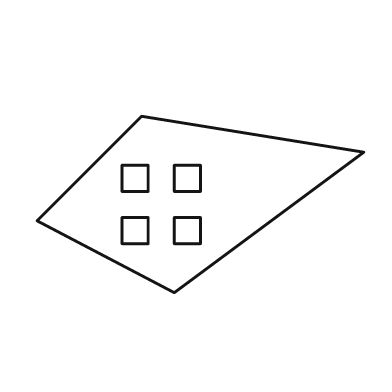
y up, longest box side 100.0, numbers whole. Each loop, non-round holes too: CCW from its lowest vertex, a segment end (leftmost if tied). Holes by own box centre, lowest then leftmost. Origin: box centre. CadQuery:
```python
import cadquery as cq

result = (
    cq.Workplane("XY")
    .moveTo(-8.0, -27.0)
    .lineTo(50.0, 16.0)
    .lineTo(-18.0, 27.0)
    .lineTo(-50.0, -5.0)
    .close()
    .moveTo(-24.0, -12.0)
    .lineTo(-16.0, -12.0)
    .lineTo(-16.0, -4.0)
    .lineTo(-24.0, -4.0)
    .close()
    .moveTo(-8.0, -12.0)
    .lineTo(0.0, -12.0)
    .lineTo(0.0, -4.0)
    .lineTo(-8.0, -4.0)
    .close()
    .moveTo(-24.0, 4.0)
    .lineTo(-16.0, 4.0)
    .lineTo(-16.0, 12.0)
    .lineTo(-24.0, 12.0)
    .close()
    .moveTo(-8.0, 4.0)
    .lineTo(0.0, 4.0)
    .lineTo(0.0, 12.0)
    .lineTo(-8.0, 12.0)
    .close()
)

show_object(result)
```